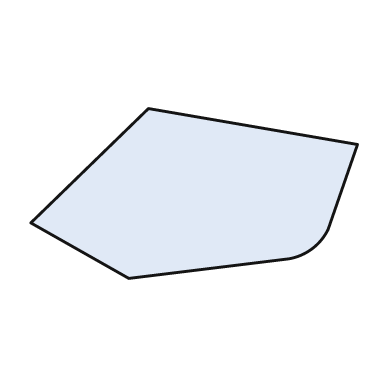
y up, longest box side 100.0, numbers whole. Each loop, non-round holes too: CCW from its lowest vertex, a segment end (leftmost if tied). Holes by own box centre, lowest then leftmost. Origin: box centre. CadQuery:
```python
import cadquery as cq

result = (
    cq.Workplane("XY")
    .moveTo(-20.0, -26.0)
    .lineTo(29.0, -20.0)
    .threePointArc((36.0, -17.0), (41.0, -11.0))
    .lineTo(50.0, 15.0)
    .lineTo(-14.0, 26.0)
    .lineTo(-50.0, -9.0)
    .close()
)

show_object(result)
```